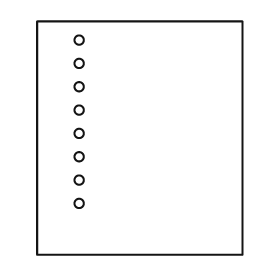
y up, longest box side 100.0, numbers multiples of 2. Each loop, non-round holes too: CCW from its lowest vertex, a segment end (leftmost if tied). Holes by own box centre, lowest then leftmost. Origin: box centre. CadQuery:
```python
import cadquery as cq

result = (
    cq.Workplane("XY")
    .moveTo(-44.0, -50.0)
    .lineTo(44.0, -50.0)
    .lineTo(44.0, 50.0)
    .lineTo(-44.0, 50.0)
    .close()
    .moveTo(-26.0, -28.0)
    .circle(2.0)
    .moveTo(-26.0, -18.0)
    .circle(2.0)
    .moveTo(-26.0, -8.0)
    .circle(2.0)
    .moveTo(-26.0, 2.0)
    .circle(2.0)
    .moveTo(-26.0, 12.0)
    .circle(2.0)
    .moveTo(-26.0, 22.0)
    .circle(2.0)
    .moveTo(-26.0, 32.0)
    .circle(2.0)
    .moveTo(-26.0, 42.0)
    .circle(2.0)
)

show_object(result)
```